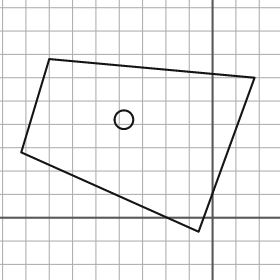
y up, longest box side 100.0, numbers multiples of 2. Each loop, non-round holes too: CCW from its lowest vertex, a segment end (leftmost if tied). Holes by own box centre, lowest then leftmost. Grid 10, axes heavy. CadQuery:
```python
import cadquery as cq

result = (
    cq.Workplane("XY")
    .moveTo(-6.0, -6.0)
    .lineTo(18.0, 60.0)
    .lineTo(-70.0, 68.0)
    .lineTo(-82.0, 28.0)
    .close()
    .moveTo(-38.0, 42.0)
    .circle(4.0)
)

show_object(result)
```